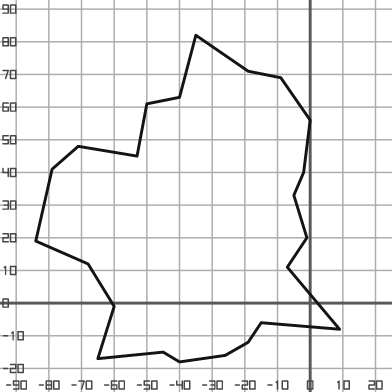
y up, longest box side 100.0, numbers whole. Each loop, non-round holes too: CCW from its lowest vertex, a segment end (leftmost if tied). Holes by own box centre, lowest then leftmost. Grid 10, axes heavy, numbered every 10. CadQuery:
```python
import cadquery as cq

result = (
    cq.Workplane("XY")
    .moveTo(-40.0, -18.0)
    .lineTo(-26.0, -16.0)
    .lineTo(-19.0, -12.0)
    .lineTo(-15.0, -6.0)
    .lineTo(9.0, -8.0)
    .lineTo(-7.0, 11.0)
    .lineTo(-1.0, 20.0)
    .lineTo(-5.0, 33.0)
    .lineTo(-2.0, 40.0)
    .lineTo(0.0, 56.0)
    .lineTo(-9.0, 69.0)
    .lineTo(-19.0, 71.0)
    .lineTo(-35.0, 82.0)
    .lineTo(-40.0, 63.0)
    .lineTo(-50.0, 61.0)
    .lineTo(-53.0, 45.0)
    .lineTo(-71.0, 48.0)
    .lineTo(-79.0, 41.0)
    .lineTo(-84.0, 19.0)
    .lineTo(-68.0, 12.0)
    .lineTo(-60.0, -1.0)
    .lineTo(-65.0, -17.0)
    .lineTo(-45.0, -15.0)
    .close()
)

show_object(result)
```